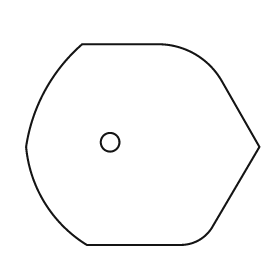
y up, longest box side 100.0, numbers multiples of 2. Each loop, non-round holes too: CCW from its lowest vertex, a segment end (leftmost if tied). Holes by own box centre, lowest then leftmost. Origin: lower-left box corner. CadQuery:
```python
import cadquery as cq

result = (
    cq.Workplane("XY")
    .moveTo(26.0, 0.0)
    .lineTo(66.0, 0.0)
    .threePointArc((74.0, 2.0), (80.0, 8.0))
    .lineTo(100.0, 42.0)
    .lineTo(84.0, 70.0)
    .threePointArc((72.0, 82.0), (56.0, 86.0))
    .lineTo(24.0, 86.0)
    .threePointArc((8.0, 66.0), (0.0, 42.0))
    .threePointArc((8.0, 18.0), (26.0, 0.0))
    .close()
    .moveTo(36.0, 44.0)
    .circle(4.0)
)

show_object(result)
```